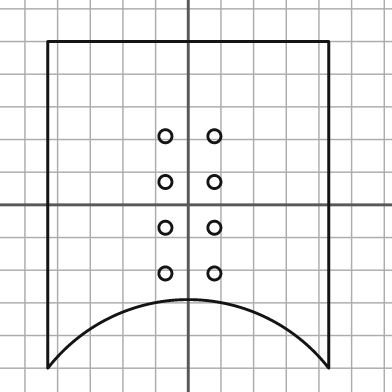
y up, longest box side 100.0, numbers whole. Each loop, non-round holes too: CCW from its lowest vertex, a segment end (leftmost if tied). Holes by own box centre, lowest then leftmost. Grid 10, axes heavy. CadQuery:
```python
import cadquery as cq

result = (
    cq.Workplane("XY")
    .moveTo(-43.0, -50.0)
    .threePointArc((0.0, -29.0), (43.0, -50.0))
    .lineTo(43.0, 50.0)
    .lineTo(-43.0, 50.0)
    .close()
    .moveTo(-7.0, -21.0)
    .circle(2.0)
    .moveTo(8.0, -21.0)
    .circle(2.0)
    .moveTo(-7.0, -7.0)
    .circle(2.0)
    .moveTo(8.0, -7.0)
    .circle(2.0)
    .moveTo(-7.0, 7.0)
    .circle(2.0)
    .moveTo(8.0, 7.0)
    .circle(2.0)
    .moveTo(-7.0, 21.0)
    .circle(2.0)
    .moveTo(8.0, 21.0)
    .circle(2.0)
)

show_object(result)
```